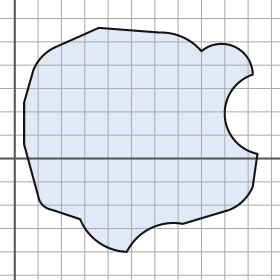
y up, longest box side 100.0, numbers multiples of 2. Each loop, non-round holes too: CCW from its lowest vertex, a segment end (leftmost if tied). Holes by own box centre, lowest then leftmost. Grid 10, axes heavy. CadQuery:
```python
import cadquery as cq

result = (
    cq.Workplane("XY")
    .moveTo(48.0, -40.0)
    .threePointArc((58.0, -30.0), (72.0, -28.0))
    .lineTo(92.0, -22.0)
    .threePointArc((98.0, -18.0), (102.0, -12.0))
    .lineTo(104.0, 2.0)
    .threePointArc((90.0, 18.0), (102.0, 36.0))
    .threePointArc((94.0, 48.0), (80.0, 46.0))
    .threePointArc((72.0, 52.0), (62.0, 54.0))
    .lineTo(36.0, 56.0)
    .lineTo(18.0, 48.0)
    .threePointArc((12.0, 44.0), (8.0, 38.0))
    .lineTo(4.0, 24.0)
    .lineTo(4.0, 6.0)
    .lineTo(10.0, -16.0)
    .threePointArc((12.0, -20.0), (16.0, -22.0))
    .lineTo(28.0, -26.0)
    .threePointArc((36.0, -36.0), (48.0, -40.0))
    .close()
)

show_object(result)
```